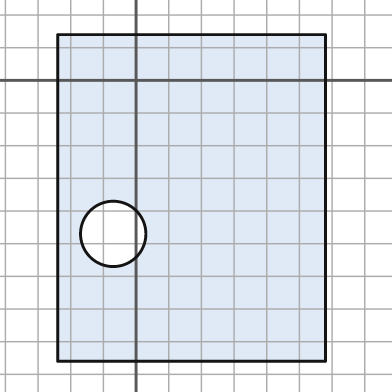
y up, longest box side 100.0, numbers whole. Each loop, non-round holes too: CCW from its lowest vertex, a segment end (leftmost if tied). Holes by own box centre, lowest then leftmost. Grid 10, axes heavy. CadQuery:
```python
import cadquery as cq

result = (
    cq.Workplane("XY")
    .moveTo(-24.0, -86.0)
    .lineTo(58.0, -86.0)
    .lineTo(58.0, 14.0)
    .lineTo(-24.0, 14.0)
    .close()
    .moveTo(-7.0, -47.0)
    .circle(10.0)
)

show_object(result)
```